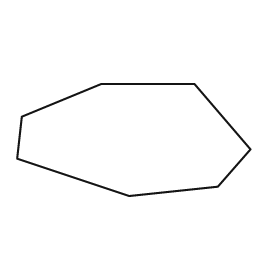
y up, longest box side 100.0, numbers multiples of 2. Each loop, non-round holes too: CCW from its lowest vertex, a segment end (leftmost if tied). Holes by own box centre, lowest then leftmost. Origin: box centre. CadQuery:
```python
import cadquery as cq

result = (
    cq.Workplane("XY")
    .moveTo(-2.0, -24.0)
    .lineTo(36.0, -20.0)
    .lineTo(50.0, -4.0)
    .lineTo(26.0, 24.0)
    .lineTo(-14.0, 24.0)
    .lineTo(-48.0, 10.0)
    .lineTo(-50.0, -8.0)
    .close()
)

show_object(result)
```